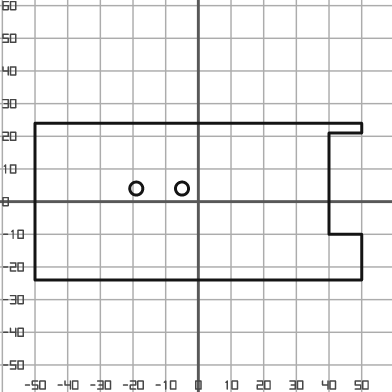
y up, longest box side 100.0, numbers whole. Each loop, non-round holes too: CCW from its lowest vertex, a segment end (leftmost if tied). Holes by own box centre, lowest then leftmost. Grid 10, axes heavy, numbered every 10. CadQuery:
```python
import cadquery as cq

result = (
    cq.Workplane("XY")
    .moveTo(-50.0, -24.0)
    .lineTo(50.0, -24.0)
    .lineTo(50.0, -10.0)
    .lineTo(40.0, -10.0)
    .lineTo(40.0, 21.0)
    .lineTo(50.0, 21.0)
    .lineTo(50.0, 24.0)
    .lineTo(-50.0, 24.0)
    .close()
    .moveTo(-19.0, 4.0)
    .circle(2.0)
    .moveTo(-5.0, 4.0)
    .circle(2.0)
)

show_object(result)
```